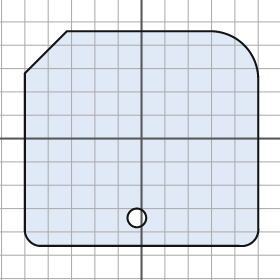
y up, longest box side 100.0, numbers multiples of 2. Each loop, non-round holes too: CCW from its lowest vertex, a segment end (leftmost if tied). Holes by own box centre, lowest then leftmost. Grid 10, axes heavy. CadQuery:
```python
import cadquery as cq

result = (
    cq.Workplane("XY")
    .moveTo(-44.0, -46.0)
    .lineTo(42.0, -46.0)
    .threePointArc((48.0, -44.0), (50.0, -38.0))
    .lineTo(50.0, 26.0)
    .threePointArc((44.0, 40.0), (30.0, 46.0))
    .lineTo(-32.0, 46.0)
    .lineTo(-50.0, 28.0)
    .lineTo(-50.0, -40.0)
    .threePointArc((-48.0, -44.0), (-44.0, -46.0))
    .close()
    .moveTo(-2.0, -34.0)
    .circle(4.0)
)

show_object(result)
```